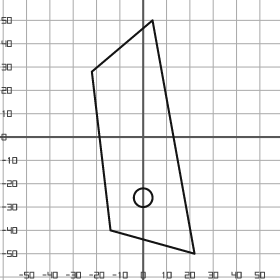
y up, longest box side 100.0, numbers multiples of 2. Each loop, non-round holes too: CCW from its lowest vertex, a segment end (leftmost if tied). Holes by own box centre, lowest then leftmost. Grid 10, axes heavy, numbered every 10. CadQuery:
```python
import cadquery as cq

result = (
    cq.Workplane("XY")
    .moveTo(22.0, -50.0)
    .lineTo(4.0, 50.0)
    .lineTo(-22.0, 28.0)
    .lineTo(-14.0, -40.0)
    .close()
    .moveTo(0.0, -26.0)
    .circle(4.0)
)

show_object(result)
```